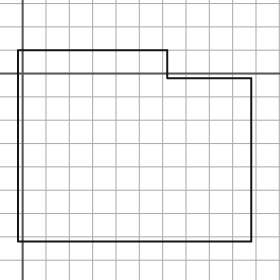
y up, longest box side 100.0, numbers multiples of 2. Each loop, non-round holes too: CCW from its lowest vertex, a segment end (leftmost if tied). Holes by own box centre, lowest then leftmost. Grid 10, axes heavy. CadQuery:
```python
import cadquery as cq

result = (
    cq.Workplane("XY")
    .moveTo(-2.0, -72.0)
    .lineTo(98.0, -72.0)
    .lineTo(98.0, -2.0)
    .lineTo(62.0, -2.0)
    .lineTo(62.0, 10.0)
    .lineTo(-2.0, 10.0)
    .close()
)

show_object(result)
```